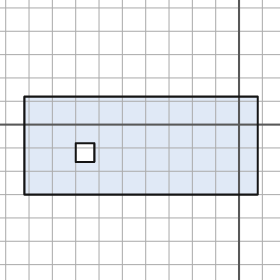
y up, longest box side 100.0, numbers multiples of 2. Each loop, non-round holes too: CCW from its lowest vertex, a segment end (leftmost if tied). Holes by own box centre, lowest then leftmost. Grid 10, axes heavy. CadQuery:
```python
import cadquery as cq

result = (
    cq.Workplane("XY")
    .moveTo(-92.0, -30.0)
    .lineTo(8.0, -30.0)
    .lineTo(8.0, 12.0)
    .lineTo(-92.0, 12.0)
    .close()
    .moveTo(-70.0, -16.0)
    .lineTo(-62.0, -16.0)
    .lineTo(-62.0, -8.0)
    .lineTo(-70.0, -8.0)
    .close()
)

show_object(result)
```